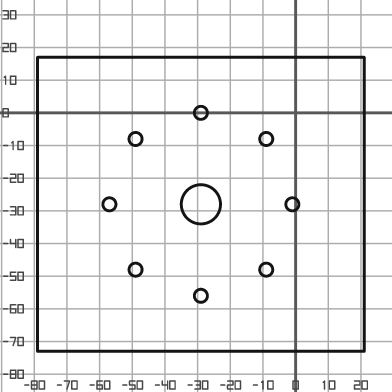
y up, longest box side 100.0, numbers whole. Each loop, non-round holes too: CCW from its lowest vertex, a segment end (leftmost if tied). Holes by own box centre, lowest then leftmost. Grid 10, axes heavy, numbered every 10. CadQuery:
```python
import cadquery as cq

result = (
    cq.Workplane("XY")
    .moveTo(-79.0, -73.0)
    .lineTo(21.0, -73.0)
    .lineTo(21.0, 17.0)
    .lineTo(-79.0, 17.0)
    .close()
    .moveTo(-29.0, -56.0)
    .circle(2.0)
    .moveTo(-49.0, -48.0)
    .circle(2.0)
    .moveTo(-9.0, -48.0)
    .circle(2.0)
    .moveTo(-57.0, -28.0)
    .circle(2.0)
    .moveTo(-29.0, -28.0)
    .circle(6.0)
    .moveTo(-1.0, -28.0)
    .circle(2.0)
    .moveTo(-49.0, -8.0)
    .circle(2.0)
    .moveTo(-9.0, -8.0)
    .circle(2.0)
    .moveTo(-29.0, 0.0)
    .circle(2.0)
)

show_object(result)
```